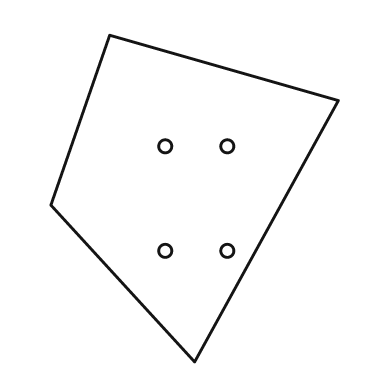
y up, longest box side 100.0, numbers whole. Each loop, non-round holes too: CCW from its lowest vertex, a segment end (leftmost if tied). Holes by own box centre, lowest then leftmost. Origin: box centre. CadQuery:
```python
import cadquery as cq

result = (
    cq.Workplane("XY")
    .moveTo(0.0, -50.0)
    .lineTo(44.0, 30.0)
    .lineTo(-26.0, 50.0)
    .lineTo(-44.0, -2.0)
    .close()
    .moveTo(-9.0, -16.0)
    .circle(2.0)
    .moveTo(10.0, -16.0)
    .circle(2.0)
    .moveTo(-9.0, 16.0)
    .circle(2.0)
    .moveTo(10.0, 16.0)
    .circle(2.0)
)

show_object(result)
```